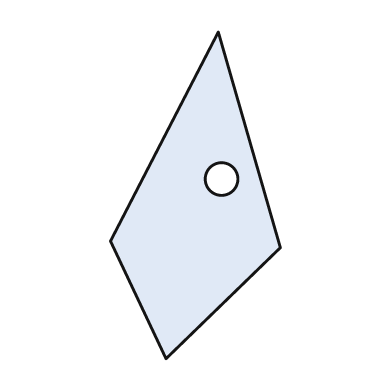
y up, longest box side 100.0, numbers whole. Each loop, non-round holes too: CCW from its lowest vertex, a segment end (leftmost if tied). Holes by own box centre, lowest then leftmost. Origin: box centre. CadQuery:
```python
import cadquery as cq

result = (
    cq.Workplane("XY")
    .moveTo(-9.0, -50.0)
    .lineTo(26.0, -16.0)
    .lineTo(7.0, 50.0)
    .lineTo(-26.0, -14.0)
    .close()
    .moveTo(8.0, 5.0)
    .circle(5.0)
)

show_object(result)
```